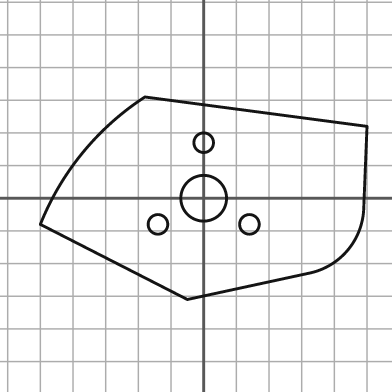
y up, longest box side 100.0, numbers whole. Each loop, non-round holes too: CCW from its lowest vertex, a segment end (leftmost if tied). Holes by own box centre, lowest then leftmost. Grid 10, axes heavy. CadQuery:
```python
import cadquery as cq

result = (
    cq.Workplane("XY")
    .moveTo(-5.0, -31.0)
    .lineTo(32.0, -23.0)
    .threePointArc((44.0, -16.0), (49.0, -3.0))
    .lineTo(50.0, 22.0)
    .lineTo(-18.0, 31.0)
    .threePointArc((-37.0, 14.0), (-50.0, -8.0))
    .close()
    .moveTo(-14.0, -8.0)
    .circle(3.0)
    .moveTo(14.0, -8.0)
    .circle(3.0)
    .moveTo(0.0, 0.0)
    .circle(7.0)
    .moveTo(0.0, 17.0)
    .circle(3.0)
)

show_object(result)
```